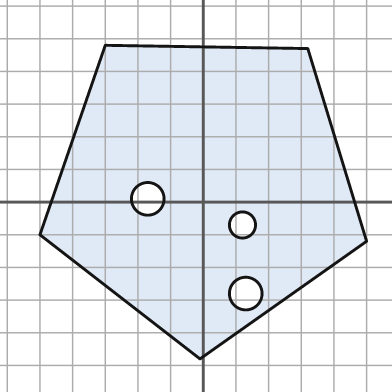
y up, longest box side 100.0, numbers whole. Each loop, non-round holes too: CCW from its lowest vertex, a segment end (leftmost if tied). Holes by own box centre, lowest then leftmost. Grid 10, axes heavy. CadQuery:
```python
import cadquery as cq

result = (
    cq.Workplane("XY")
    .moveTo(-1.0, -48.0)
    .lineTo(50.0, -12.0)
    .lineTo(32.0, 47.0)
    .lineTo(-30.0, 48.0)
    .lineTo(-50.0, -10.0)
    .close()
    .moveTo(13.0, -28.0)
    .circle(5.0)
    .moveTo(12.0, -7.0)
    .circle(4.0)
    .moveTo(-17.0, 1.0)
    .circle(5.0)
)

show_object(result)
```